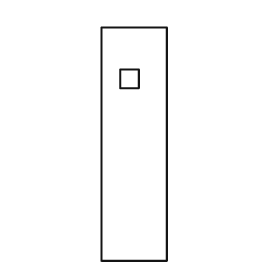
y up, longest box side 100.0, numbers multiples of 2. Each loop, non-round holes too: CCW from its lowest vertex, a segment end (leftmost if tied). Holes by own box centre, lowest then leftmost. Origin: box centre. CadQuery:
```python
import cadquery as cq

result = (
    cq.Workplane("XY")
    .moveTo(-14.0, -50.0)
    .lineTo(14.0, -50.0)
    .lineTo(14.0, 50.0)
    .lineTo(-14.0, 50.0)
    .close()
    .moveTo(-6.0, 24.0)
    .lineTo(2.0, 24.0)
    .lineTo(2.0, 32.0)
    .lineTo(-6.0, 32.0)
    .close()
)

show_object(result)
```